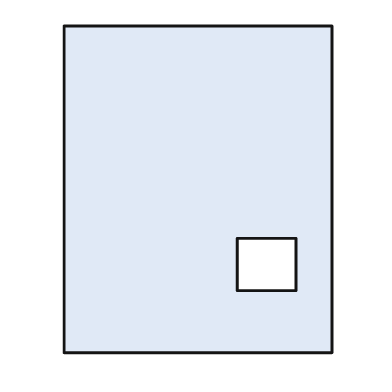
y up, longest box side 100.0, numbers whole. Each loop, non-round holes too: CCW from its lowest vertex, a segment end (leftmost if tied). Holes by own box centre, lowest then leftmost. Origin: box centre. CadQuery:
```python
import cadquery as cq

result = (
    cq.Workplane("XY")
    .moveTo(-41.0, -50.0)
    .lineTo(41.0, -50.0)
    .lineTo(41.0, 50.0)
    .lineTo(-41.0, 50.0)
    .close()
    .moveTo(12.0, -31.0)
    .lineTo(30.0, -31.0)
    .lineTo(30.0, -15.0)
    .lineTo(12.0, -15.0)
    .close()
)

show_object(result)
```